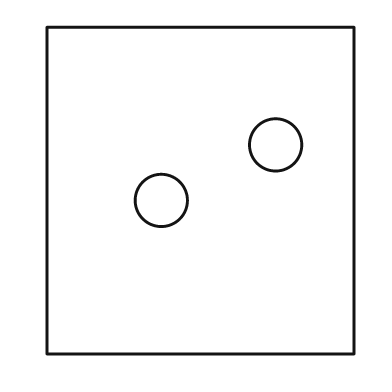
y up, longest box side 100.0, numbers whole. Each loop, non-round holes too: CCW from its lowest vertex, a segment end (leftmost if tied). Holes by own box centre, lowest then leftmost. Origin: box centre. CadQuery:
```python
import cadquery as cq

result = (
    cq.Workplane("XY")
    .moveTo(-47.0, -50.0)
    .lineTo(47.0, -50.0)
    .lineTo(47.0, 50.0)
    .lineTo(-47.0, 50.0)
    .close()
    .moveTo(-12.0, -3.0)
    .circle(8.0)
    .moveTo(23.0, 14.0)
    .circle(8.0)
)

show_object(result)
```